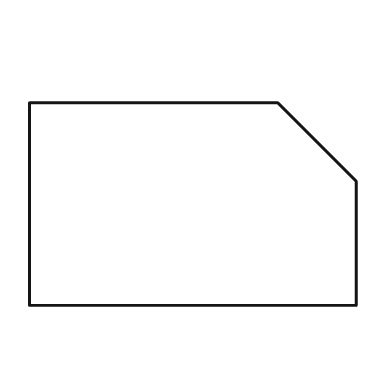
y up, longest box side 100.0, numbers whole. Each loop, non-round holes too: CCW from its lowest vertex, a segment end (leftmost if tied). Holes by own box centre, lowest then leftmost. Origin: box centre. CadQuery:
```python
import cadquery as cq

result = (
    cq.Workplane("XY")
    .moveTo(-50.0, -31.0)
    .lineTo(50.0, -31.0)
    .lineTo(50.0, 7.0)
    .lineTo(26.0, 31.0)
    .lineTo(-50.0, 31.0)
    .close()
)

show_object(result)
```